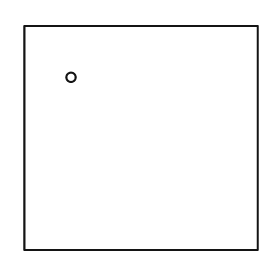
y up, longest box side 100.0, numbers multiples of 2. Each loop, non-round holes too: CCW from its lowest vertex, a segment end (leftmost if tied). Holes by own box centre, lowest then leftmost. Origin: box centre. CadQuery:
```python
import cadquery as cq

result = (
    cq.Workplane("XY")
    .moveTo(-50.0, -48.0)
    .lineTo(50.0, -48.0)
    .lineTo(50.0, 48.0)
    .lineTo(-50.0, 48.0)
    .close()
    .moveTo(-30.0, 26.0)
    .circle(2.0)
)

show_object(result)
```